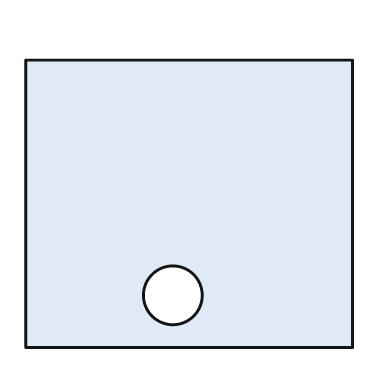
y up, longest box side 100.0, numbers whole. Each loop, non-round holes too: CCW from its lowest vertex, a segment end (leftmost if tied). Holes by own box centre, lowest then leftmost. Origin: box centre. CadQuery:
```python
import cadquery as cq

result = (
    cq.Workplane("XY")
    .moveTo(-50.0, -44.0)
    .lineTo(50.0, -44.0)
    .lineTo(50.0, 44.0)
    .lineTo(-50.0, 44.0)
    .close()
    .moveTo(-5.0, -28.0)
    .circle(9.0)
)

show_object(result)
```